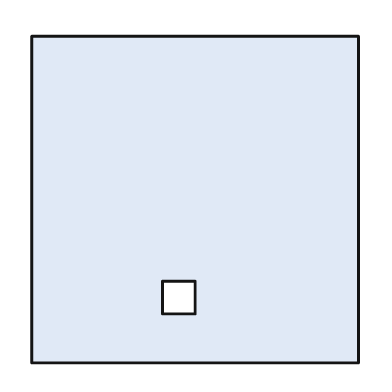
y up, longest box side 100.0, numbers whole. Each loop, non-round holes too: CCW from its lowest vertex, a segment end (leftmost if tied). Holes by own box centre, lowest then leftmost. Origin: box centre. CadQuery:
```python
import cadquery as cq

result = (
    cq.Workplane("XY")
    .moveTo(-50.0, -50.0)
    .lineTo(50.0, -50.0)
    .lineTo(50.0, 50.0)
    .lineTo(-50.0, 50.0)
    .close()
    .moveTo(-10.0, -35.0)
    .lineTo(0.0, -35.0)
    .lineTo(0.0, -25.0)
    .lineTo(-10.0, -25.0)
    .close()
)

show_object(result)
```